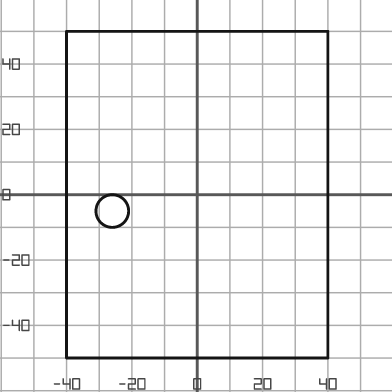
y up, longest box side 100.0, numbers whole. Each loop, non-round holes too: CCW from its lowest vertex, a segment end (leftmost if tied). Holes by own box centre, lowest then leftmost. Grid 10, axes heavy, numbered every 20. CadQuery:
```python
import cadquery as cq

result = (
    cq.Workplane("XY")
    .moveTo(-40.0, -50.0)
    .lineTo(40.0, -50.0)
    .lineTo(40.0, 50.0)
    .lineTo(-40.0, 50.0)
    .close()
    .moveTo(-26.0, -5.0)
    .circle(5.0)
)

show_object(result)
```